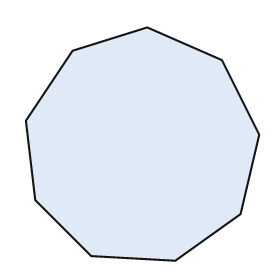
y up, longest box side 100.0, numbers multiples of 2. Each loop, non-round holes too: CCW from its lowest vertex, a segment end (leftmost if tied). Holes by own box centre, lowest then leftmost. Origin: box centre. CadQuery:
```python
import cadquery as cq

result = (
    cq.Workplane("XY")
    .moveTo(14.0, -50.0)
    .lineTo(42.0, -30.0)
    .lineTo(50.0, 4.0)
    .lineTo(34.0, 36.0)
    .lineTo(2.0, 50.0)
    .lineTo(-30.0, 40.0)
    .lineTo(-50.0, 10.0)
    .lineTo(-46.0, -24.0)
    .lineTo(-22.0, -48.0)
    .close()
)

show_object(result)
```